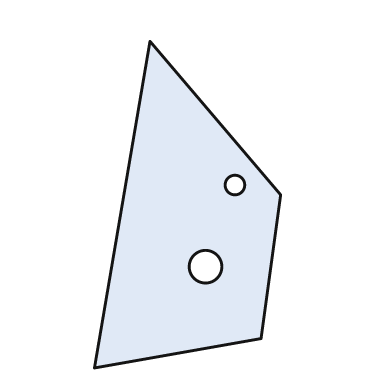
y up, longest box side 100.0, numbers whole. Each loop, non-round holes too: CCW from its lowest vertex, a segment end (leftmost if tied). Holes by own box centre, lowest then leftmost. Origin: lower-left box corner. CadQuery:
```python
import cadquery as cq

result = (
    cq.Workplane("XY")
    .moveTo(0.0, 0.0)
    .lineTo(51.0, 9.0)
    .lineTo(57.0, 53.0)
    .lineTo(17.0, 100.0)
    .close()
    .moveTo(34.0, 31.0)
    .circle(5.0)
    .moveTo(43.0, 56.0)
    .circle(3.0)
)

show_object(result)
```